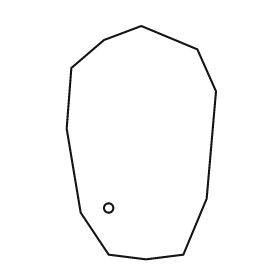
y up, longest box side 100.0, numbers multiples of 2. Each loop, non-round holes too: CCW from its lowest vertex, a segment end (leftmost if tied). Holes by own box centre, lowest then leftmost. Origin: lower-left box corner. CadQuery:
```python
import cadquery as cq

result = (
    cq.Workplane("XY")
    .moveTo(34.0, 0.0)
    .lineTo(50.0, 2.0)
    .lineTo(60.0, 26.0)
    .lineTo(64.0, 72.0)
    .lineTo(56.0, 90.0)
    .lineTo(32.0, 100.0)
    .lineTo(16.0, 94.0)
    .lineTo(2.0, 82.0)
    .lineTo(0.0, 56.0)
    .lineTo(6.0, 20.0)
    .lineTo(18.0, 2.0)
    .close()
    .moveTo(18.0, 22.0)
    .circle(2.0)
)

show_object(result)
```